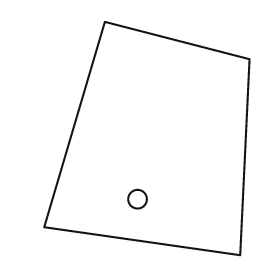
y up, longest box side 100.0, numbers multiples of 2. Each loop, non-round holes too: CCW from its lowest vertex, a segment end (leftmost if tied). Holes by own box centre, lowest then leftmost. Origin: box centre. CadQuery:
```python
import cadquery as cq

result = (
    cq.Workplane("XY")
    .moveTo(40.0, -50.0)
    .lineTo(44.0, 34.0)
    .lineTo(-18.0, 50.0)
    .lineTo(-44.0, -38.0)
    .close()
    .moveTo(-4.0, -26.0)
    .circle(4.0)
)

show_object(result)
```